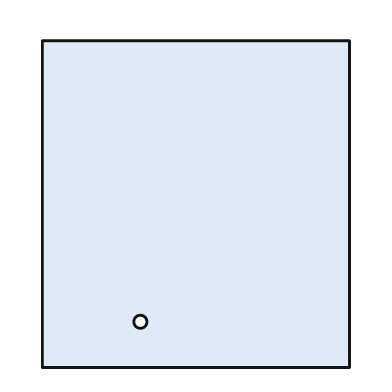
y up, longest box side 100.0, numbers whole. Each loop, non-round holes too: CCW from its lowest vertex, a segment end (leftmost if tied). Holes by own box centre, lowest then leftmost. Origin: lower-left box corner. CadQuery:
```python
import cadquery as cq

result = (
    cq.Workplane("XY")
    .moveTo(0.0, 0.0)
    .lineTo(94.0, 0.0)
    .lineTo(94.0, 100.0)
    .lineTo(0.0, 100.0)
    .close()
    .moveTo(30.0, 14.0)
    .circle(2.0)
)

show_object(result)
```